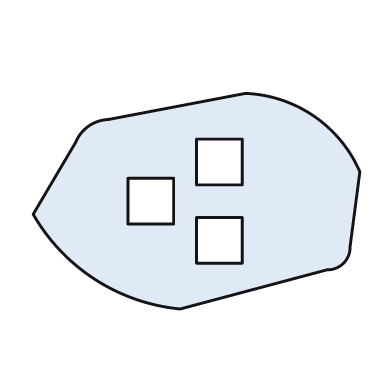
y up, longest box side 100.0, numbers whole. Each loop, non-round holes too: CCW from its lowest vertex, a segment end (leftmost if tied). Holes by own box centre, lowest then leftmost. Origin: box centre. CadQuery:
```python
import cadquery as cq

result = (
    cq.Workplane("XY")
    .moveTo(-5.0, -33.0)
    .lineTo(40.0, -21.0)
    .threePointArc((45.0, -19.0), (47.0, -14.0))
    .lineTo(50.0, 9.0)
    .threePointArc((36.0, 26.0), (15.0, 33.0))
    .lineTo(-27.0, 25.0)
    .threePointArc((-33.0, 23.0), (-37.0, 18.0))
    .lineTo(-50.0, -4.0)
    .threePointArc((-31.0, -24.0), (-5.0, -33.0))
    .close()
    .moveTo(0.0, -19.0)
    .lineTo(14.0, -19.0)
    .lineTo(14.0, -5.0)
    .lineTo(0.0, -5.0)
    .close()
    .moveTo(-21.0, -7.0)
    .lineTo(-7.0, -7.0)
    .lineTo(-7.0, 7.0)
    .lineTo(-21.0, 7.0)
    .close()
    .moveTo(0.0, 5.0)
    .lineTo(14.0, 5.0)
    .lineTo(14.0, 19.0)
    .lineTo(0.0, 19.0)
    .close()
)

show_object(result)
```